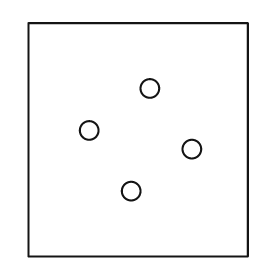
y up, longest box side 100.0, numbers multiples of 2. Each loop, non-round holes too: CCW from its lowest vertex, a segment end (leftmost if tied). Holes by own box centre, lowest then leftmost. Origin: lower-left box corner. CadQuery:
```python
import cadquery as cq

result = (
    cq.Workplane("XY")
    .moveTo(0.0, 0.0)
    .lineTo(94.0, 0.0)
    .lineTo(94.0, 100.0)
    .lineTo(0.0, 100.0)
    .close()
    .moveTo(44.0, 28.0)
    .circle(4.0)
    .moveTo(70.0, 46.0)
    .circle(4.0)
    .moveTo(26.0, 54.0)
    .circle(4.0)
    .moveTo(52.0, 72.0)
    .circle(4.0)
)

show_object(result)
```